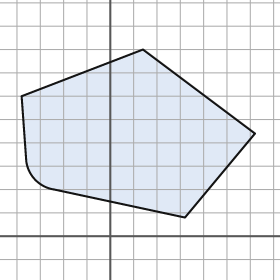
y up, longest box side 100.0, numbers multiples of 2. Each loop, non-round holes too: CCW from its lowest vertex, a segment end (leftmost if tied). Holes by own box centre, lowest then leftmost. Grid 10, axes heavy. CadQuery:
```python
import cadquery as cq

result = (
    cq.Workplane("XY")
    .moveTo(32.0, 8.0)
    .lineTo(62.0, 44.0)
    .lineTo(14.0, 80.0)
    .lineTo(-38.0, 60.0)
    .lineTo(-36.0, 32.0)
    .threePointArc((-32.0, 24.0), (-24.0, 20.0))
    .close()
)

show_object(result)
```